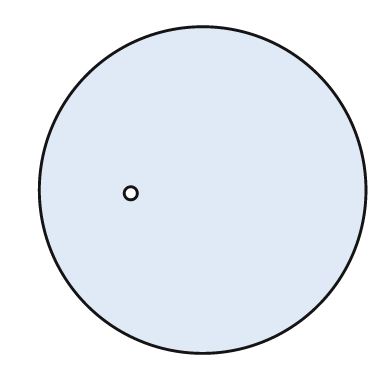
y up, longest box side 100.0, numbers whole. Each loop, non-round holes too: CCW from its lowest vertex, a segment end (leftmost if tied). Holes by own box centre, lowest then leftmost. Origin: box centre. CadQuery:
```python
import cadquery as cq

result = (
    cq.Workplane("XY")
    .moveTo(0.0, 0.0)
    .circle(50.0)
    .moveTo(-22.0, -1.0)
    .circle(2.0)
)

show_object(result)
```